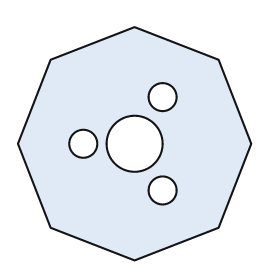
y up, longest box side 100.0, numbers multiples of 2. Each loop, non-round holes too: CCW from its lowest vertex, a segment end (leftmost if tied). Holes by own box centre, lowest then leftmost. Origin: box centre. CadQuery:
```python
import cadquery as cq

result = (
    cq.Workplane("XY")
    .moveTo(0.0, -50.0)
    .lineTo(36.0, -36.0)
    .lineTo(50.0, 0.0)
    .lineTo(36.0, 36.0)
    .lineTo(0.0, 50.0)
    .lineTo(-36.0, 36.0)
    .lineTo(-50.0, 0.0)
    .lineTo(-36.0, -36.0)
    .close()
    .moveTo(12.0, -20.0)
    .circle(6.0)
    .moveTo(-22.0, 0.0)
    .circle(6.0)
    .moveTo(0.0, 0.0)
    .circle(12.0)
    .moveTo(12.0, 20.0)
    .circle(6.0)
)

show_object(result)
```